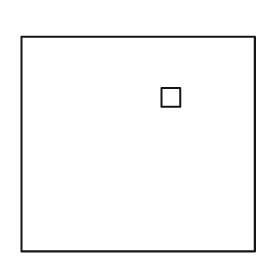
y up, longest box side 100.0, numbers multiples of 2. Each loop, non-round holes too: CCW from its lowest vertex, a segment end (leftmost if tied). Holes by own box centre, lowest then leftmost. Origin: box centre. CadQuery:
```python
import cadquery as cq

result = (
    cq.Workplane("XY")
    .moveTo(-50.0, -46.0)
    .lineTo(50.0, -46.0)
    .lineTo(50.0, 46.0)
    .lineTo(-50.0, 46.0)
    .close()
    .moveTo(10.0, 16.0)
    .lineTo(18.0, 16.0)
    .lineTo(18.0, 24.0)
    .lineTo(10.0, 24.0)
    .close()
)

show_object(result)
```